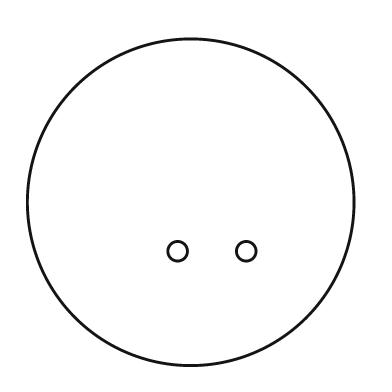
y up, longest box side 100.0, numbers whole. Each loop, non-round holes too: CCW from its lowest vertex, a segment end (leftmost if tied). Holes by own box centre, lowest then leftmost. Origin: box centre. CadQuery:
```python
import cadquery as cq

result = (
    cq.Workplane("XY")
    .moveTo(0.0, 0.0)
    .circle(50.0)
    .moveTo(-4.0, -15.0)
    .circle(3.0)
    .moveTo(17.0, -15.0)
    .circle(3.0)
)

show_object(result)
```